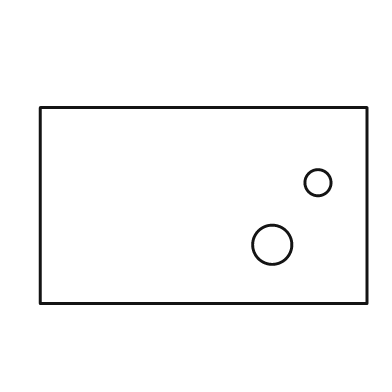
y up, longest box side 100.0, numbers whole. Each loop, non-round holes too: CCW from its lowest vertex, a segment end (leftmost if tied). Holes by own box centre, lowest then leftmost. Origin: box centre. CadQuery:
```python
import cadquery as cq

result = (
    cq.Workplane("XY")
    .moveTo(-50.0, -30.0)
    .lineTo(50.0, -30.0)
    .lineTo(50.0, 30.0)
    .lineTo(-50.0, 30.0)
    .close()
    .moveTo(21.0, -12.0)
    .circle(6.0)
    .moveTo(35.0, 7.0)
    .circle(4.0)
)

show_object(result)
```